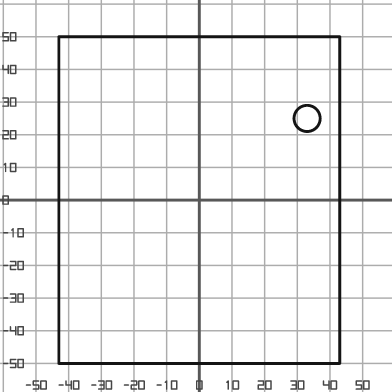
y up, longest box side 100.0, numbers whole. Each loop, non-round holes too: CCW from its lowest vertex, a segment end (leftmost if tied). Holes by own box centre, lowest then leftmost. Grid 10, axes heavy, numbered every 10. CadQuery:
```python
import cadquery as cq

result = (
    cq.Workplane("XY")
    .moveTo(-43.0, -50.0)
    .lineTo(43.0, -50.0)
    .lineTo(43.0, 50.0)
    .lineTo(-43.0, 50.0)
    .close()
    .moveTo(33.0, 25.0)
    .circle(4.0)
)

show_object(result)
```